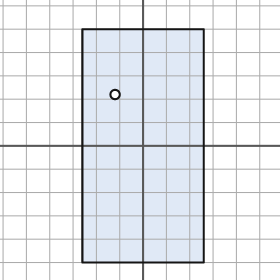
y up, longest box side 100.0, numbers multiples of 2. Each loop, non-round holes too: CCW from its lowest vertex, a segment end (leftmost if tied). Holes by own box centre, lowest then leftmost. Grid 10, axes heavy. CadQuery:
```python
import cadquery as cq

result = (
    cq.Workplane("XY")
    .moveTo(-26.0, -50.0)
    .lineTo(26.0, -50.0)
    .lineTo(26.0, 50.0)
    .lineTo(-26.0, 50.0)
    .close()
    .moveTo(-12.0, 22.0)
    .circle(2.0)
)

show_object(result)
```